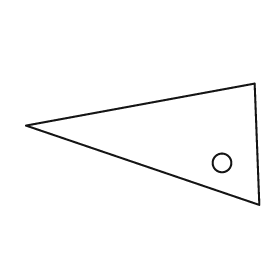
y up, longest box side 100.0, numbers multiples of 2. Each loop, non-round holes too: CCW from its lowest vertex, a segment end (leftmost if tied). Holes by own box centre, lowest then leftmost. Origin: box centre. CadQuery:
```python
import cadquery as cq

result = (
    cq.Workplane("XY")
    .moveTo(50.0, -26.0)
    .lineTo(48.0, 26.0)
    .lineTo(-50.0, 8.0)
    .close()
    .moveTo(34.0, -8.0)
    .circle(4.0)
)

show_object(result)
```